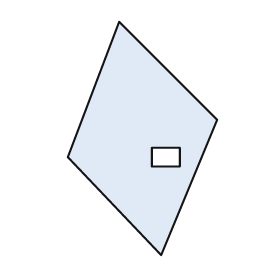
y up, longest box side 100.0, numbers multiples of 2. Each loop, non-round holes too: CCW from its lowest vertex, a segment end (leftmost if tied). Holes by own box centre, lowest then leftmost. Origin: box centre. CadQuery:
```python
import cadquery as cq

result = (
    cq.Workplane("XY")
    .moveTo(8.0, -50.0)
    .lineTo(32.0, 8.0)
    .lineTo(-10.0, 50.0)
    .lineTo(-32.0, -8.0)
    .close()
    .moveTo(4.0, -12.0)
    .lineTo(16.0, -12.0)
    .lineTo(16.0, -4.0)
    .lineTo(4.0, -4.0)
    .close()
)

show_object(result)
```